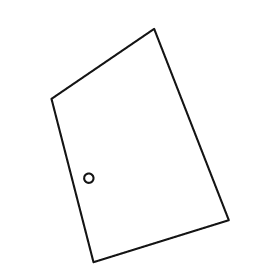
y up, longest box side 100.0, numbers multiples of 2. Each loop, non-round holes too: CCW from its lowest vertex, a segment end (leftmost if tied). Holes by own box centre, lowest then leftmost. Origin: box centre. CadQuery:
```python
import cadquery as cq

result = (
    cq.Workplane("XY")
    .moveTo(-20.0, -50.0)
    .lineTo(38.0, -32.0)
    .lineTo(6.0, 50.0)
    .lineTo(-38.0, 20.0)
    .close()
    .moveTo(-22.0, -14.0)
    .circle(2.0)
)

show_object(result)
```